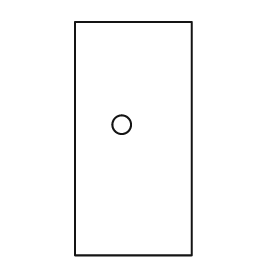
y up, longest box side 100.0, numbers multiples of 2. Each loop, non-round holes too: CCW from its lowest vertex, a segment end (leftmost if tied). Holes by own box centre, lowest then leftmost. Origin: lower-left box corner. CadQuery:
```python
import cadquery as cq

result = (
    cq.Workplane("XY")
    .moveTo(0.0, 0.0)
    .lineTo(50.0, 0.0)
    .lineTo(50.0, 100.0)
    .lineTo(0.0, 100.0)
    .close()
    .moveTo(20.0, 56.0)
    .circle(4.0)
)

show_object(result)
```